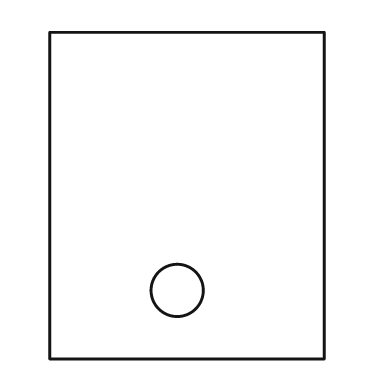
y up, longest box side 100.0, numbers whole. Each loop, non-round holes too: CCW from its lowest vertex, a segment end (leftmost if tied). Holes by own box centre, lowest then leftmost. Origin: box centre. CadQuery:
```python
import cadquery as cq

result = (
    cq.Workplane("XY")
    .moveTo(-42.0, -50.0)
    .lineTo(42.0, -50.0)
    .lineTo(42.0, 50.0)
    .lineTo(-42.0, 50.0)
    .close()
    .moveTo(-3.0, -29.0)
    .circle(8.0)
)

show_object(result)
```